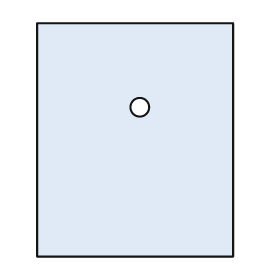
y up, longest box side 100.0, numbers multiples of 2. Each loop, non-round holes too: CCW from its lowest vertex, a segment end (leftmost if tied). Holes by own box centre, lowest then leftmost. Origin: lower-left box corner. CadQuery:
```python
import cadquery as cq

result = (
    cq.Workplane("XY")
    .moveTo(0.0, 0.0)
    .lineTo(84.0, 0.0)
    .lineTo(84.0, 100.0)
    .lineTo(0.0, 100.0)
    .close()
    .moveTo(44.0, 64.0)
    .circle(4.0)
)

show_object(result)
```